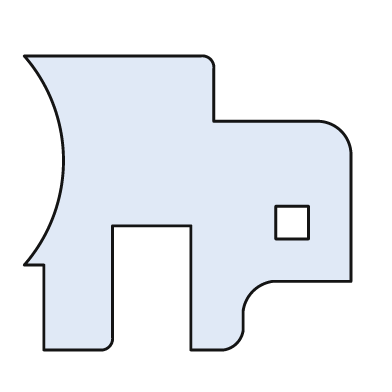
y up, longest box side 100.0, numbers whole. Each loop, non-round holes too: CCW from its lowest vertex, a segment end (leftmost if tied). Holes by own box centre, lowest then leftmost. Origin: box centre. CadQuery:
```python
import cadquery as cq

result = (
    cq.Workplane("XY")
    .moveTo(-44.0, -45.0)
    .lineTo(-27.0, -45.0)
    .threePointArc((-24.0, -44.0), (-23.0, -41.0))
    .lineTo(-23.0, -7.0)
    .lineTo(1.0, -7.0)
    .lineTo(1.0, -45.0)
    .lineTo(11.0, -45.0)
    .threePointArc((15.0, -43.0), (17.0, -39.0))
    .lineTo(17.0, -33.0)
    .threePointArc((20.0, -27.0), (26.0, -24.0))
    .lineTo(50.0, -24.0)
    .lineTo(50.0, 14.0)
    .threePointArc((47.0, 22.0), (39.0, 25.0))
    .lineTo(8.0, 25.0)
    .lineTo(8.0, 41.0)
    .threePointArc((7.0, 44.0), (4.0, 45.0))
    .lineTo(-50.0, 45.0)
    .threePointArc((-38.0, 13.0), (-50.0, -19.0))
    .lineTo(-44.0, -19.0)
    .close()
    .moveTo(27.0, -11.0)
    .lineTo(37.0, -11.0)
    .lineTo(37.0, -1.0)
    .lineTo(27.0, -1.0)
    .close()
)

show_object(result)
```